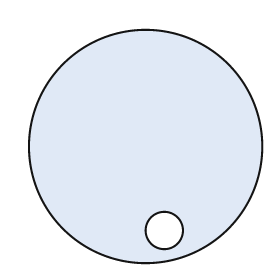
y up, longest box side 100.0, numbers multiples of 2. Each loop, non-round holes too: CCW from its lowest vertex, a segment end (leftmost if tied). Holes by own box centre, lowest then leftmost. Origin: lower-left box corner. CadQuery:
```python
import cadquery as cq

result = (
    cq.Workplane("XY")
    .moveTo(50.0, 50.0)
    .circle(50.0)
    .moveTo(58.0, 14.0)
    .circle(8.0)
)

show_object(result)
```